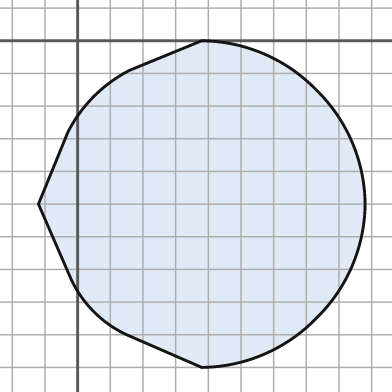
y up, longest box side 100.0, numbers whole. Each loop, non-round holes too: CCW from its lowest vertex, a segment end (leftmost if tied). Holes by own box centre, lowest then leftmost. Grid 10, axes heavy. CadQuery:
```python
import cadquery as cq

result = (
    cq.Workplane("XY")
    .moveTo(38.0, -100.0)
    .threePointArc((57.0, -96.0), (73.0, -85.0))
    .threePointArc((84.0, -69.0), (88.0, -50.0))
    .threePointArc((84.0, -31.0), (73.0, -15.0))
    .threePointArc((57.0, -4.0), (38.0, 0.0))
    .lineTo(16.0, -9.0)
    .threePointArc((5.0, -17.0), (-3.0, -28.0))
    .lineTo(-12.0, -50.0)
    .lineTo(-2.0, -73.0)
    .threePointArc((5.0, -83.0), (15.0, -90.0))
    .close()
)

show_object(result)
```